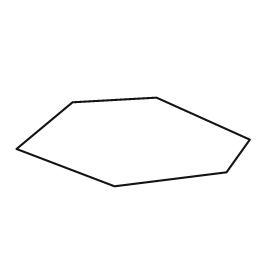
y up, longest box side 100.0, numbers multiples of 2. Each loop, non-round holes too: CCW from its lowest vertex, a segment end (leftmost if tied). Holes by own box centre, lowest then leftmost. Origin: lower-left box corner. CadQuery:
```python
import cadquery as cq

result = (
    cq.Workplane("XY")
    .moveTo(42.0, 0.0)
    .lineTo(90.0, 6.0)
    .lineTo(100.0, 20.0)
    .lineTo(60.0, 38.0)
    .lineTo(24.0, 36.0)
    .lineTo(0.0, 16.0)
    .close()
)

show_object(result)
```